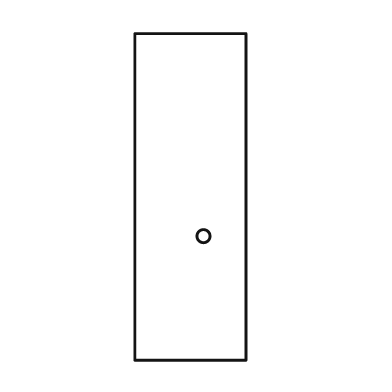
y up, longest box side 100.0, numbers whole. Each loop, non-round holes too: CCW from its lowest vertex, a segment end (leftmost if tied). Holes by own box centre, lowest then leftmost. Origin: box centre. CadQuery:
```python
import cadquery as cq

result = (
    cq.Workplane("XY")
    .moveTo(-17.0, -50.0)
    .lineTo(17.0, -50.0)
    .lineTo(17.0, 50.0)
    .lineTo(-17.0, 50.0)
    .close()
    .moveTo(4.0, -12.0)
    .circle(2.0)
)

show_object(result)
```